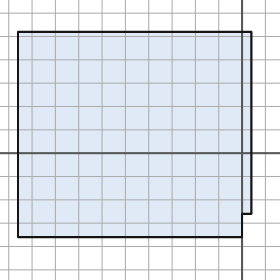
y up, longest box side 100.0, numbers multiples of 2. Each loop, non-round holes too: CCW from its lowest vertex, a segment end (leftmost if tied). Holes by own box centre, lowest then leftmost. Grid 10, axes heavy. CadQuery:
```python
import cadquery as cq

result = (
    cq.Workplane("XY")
    .moveTo(-96.0, -36.0)
    .lineTo(0.0, -36.0)
    .lineTo(0.0, -26.0)
    .lineTo(4.0, -26.0)
    .lineTo(4.0, 52.0)
    .lineTo(-96.0, 52.0)
    .close()
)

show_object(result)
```